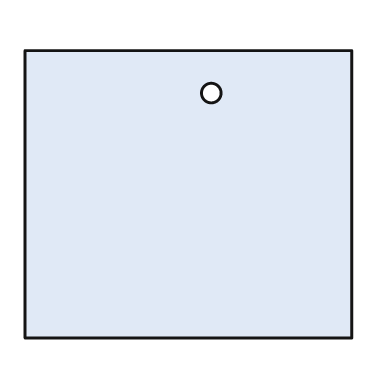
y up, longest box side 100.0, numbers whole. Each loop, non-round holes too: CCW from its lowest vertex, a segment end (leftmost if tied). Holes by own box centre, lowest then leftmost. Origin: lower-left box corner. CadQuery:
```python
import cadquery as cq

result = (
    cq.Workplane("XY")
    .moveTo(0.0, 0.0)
    .lineTo(100.0, 0.0)
    .lineTo(100.0, 88.0)
    .lineTo(0.0, 88.0)
    .close()
    .moveTo(57.0, 75.0)
    .circle(3.0)
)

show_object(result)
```